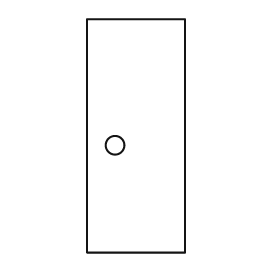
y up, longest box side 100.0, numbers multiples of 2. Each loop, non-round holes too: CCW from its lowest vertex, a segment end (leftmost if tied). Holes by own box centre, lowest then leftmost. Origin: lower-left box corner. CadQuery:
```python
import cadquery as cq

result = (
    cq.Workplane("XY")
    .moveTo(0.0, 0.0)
    .lineTo(42.0, 0.0)
    .lineTo(42.0, 100.0)
    .lineTo(0.0, 100.0)
    .close()
    .moveTo(12.0, 46.0)
    .circle(4.0)
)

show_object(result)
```